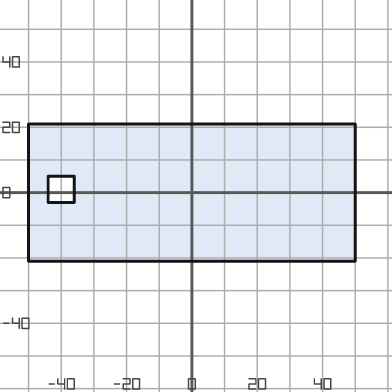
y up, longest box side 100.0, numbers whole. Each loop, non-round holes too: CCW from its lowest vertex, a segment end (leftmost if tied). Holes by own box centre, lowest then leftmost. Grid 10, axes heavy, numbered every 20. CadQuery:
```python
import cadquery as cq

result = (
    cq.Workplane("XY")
    .moveTo(-50.0, -21.0)
    .lineTo(50.0, -21.0)
    .lineTo(50.0, 21.0)
    .lineTo(-50.0, 21.0)
    .close()
    .moveTo(-44.0, -3.0)
    .lineTo(-36.0, -3.0)
    .lineTo(-36.0, 5.0)
    .lineTo(-44.0, 5.0)
    .close()
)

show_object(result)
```